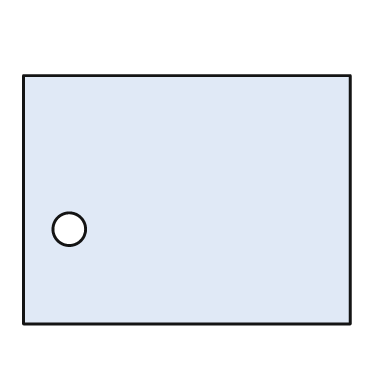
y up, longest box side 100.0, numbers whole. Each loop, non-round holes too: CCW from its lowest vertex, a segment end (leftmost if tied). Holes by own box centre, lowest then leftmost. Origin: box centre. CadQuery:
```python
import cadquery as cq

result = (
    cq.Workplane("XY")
    .moveTo(-50.0, -38.0)
    .lineTo(50.0, -38.0)
    .lineTo(50.0, 38.0)
    .lineTo(-50.0, 38.0)
    .close()
    .moveTo(-36.0, -9.0)
    .circle(5.0)
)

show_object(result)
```